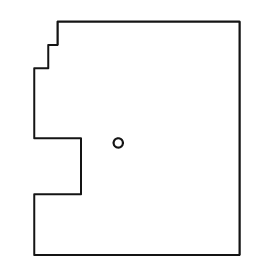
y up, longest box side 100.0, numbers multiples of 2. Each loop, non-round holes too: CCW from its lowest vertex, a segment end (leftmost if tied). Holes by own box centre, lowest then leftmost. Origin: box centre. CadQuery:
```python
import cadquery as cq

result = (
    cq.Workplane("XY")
    .moveTo(-44.0, -50.0)
    .lineTo(44.0, -50.0)
    .lineTo(44.0, 50.0)
    .lineTo(-34.0, 50.0)
    .lineTo(-34.0, 40.0)
    .lineTo(-38.0, 40.0)
    .lineTo(-38.0, 30.0)
    .lineTo(-44.0, 30.0)
    .lineTo(-44.0, 0.0)
    .lineTo(-24.0, 0.0)
    .lineTo(-24.0, -24.0)
    .lineTo(-44.0, -24.0)
    .close()
    .moveTo(-8.0, -2.0)
    .circle(2.0)
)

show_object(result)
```